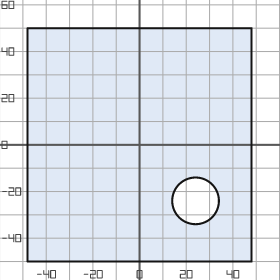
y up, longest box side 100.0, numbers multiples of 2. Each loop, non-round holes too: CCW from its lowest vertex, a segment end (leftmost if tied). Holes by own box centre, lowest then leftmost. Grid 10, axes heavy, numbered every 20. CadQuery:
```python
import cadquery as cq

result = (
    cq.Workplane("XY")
    .moveTo(-48.0, -50.0)
    .lineTo(48.0, -50.0)
    .lineTo(48.0, 50.0)
    .lineTo(-48.0, 50.0)
    .close()
    .moveTo(24.0, -24.0)
    .circle(10.0)
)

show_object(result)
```